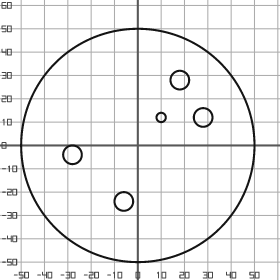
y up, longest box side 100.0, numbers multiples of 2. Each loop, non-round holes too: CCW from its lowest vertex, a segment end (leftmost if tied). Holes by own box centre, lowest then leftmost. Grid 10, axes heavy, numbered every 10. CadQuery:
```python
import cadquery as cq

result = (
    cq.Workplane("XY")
    .moveTo(0.0, 0.0)
    .circle(50.0)
    .moveTo(-6.0, -24.0)
    .circle(4.0)
    .moveTo(-28.0, -4.0)
    .circle(4.0)
    .moveTo(10.0, 12.0)
    .circle(2.0)
    .moveTo(28.0, 12.0)
    .circle(4.0)
    .moveTo(18.0, 28.0)
    .circle(4.0)
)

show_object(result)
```